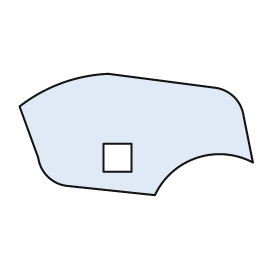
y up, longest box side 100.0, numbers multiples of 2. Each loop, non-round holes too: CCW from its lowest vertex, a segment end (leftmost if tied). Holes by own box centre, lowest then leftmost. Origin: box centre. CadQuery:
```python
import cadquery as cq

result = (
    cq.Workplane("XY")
    .moveTo(8.0, -26.0)
    .threePointArc((26.0, -10.0), (50.0, -12.0))
    .lineTo(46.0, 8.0)
    .threePointArc((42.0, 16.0), (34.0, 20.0))
    .lineTo(-12.0, 26.0)
    .threePointArc((-32.0, 22.0), (-50.0, 12.0))
    .lineTo(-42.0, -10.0)
    .threePointArc((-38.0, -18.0), (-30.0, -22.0))
    .close()
    .moveTo(-14.0, -16.0)
    .lineTo(-2.0, -16.0)
    .lineTo(-2.0, -4.0)
    .lineTo(-14.0, -4.0)
    .close()
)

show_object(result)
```